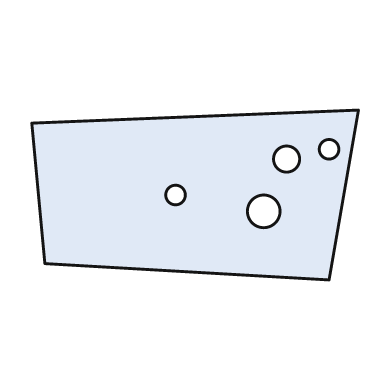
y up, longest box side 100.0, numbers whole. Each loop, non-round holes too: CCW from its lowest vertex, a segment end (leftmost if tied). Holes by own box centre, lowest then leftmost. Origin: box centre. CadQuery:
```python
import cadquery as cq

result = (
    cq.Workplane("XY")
    .moveTo(41.0, -26.0)
    .lineTo(50.0, 26.0)
    .lineTo(-50.0, 22.0)
    .lineTo(-46.0, -21.0)
    .close()
    .moveTo(21.0, -5.0)
    .circle(5.0)
    .moveTo(-6.0, 0.0)
    .circle(3.0)
    .moveTo(28.0, 11.0)
    .circle(4.0)
    .moveTo(41.0, 14.0)
    .circle(3.0)
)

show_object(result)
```